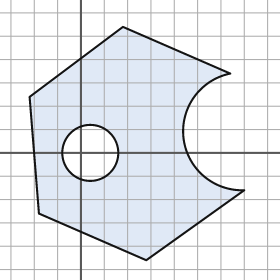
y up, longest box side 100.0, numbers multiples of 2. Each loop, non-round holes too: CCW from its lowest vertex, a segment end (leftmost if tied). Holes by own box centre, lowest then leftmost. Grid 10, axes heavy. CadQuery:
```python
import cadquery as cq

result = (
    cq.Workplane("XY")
    .moveTo(28.0, -46.0)
    .lineTo(70.0, -16.0)
    .threePointArc((44.0, 6.0), (64.0, 34.0))
    .lineTo(18.0, 54.0)
    .lineTo(-22.0, 24.0)
    .lineTo(-18.0, -26.0)
    .close()
    .moveTo(4.0, 0.0)
    .circle(12.0)
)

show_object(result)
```